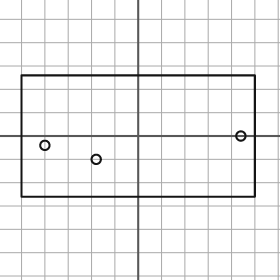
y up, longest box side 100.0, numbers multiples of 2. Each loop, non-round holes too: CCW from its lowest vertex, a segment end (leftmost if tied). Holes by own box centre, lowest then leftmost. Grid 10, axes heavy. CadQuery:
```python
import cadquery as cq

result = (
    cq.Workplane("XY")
    .moveTo(-50.0, -26.0)
    .lineTo(50.0, -26.0)
    .lineTo(50.0, 26.0)
    .lineTo(-50.0, 26.0)
    .close()
    .moveTo(-18.0, -10.0)
    .circle(2.0)
    .moveTo(-40.0, -4.0)
    .circle(2.0)
    .moveTo(44.0, 0.0)
    .circle(2.0)
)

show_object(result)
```